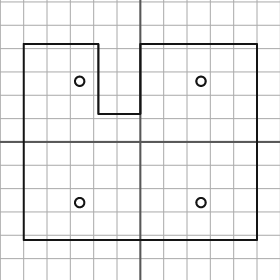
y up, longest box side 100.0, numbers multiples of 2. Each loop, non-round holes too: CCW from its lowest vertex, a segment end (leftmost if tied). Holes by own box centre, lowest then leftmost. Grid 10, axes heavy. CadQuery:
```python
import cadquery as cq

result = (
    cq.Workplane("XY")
    .moveTo(-50.0, -42.0)
    .lineTo(50.0, -42.0)
    .lineTo(50.0, 42.0)
    .lineTo(0.0, 42.0)
    .lineTo(0.0, 12.0)
    .lineTo(-18.0, 12.0)
    .lineTo(-18.0, 42.0)
    .lineTo(-50.0, 42.0)
    .close()
    .moveTo(-26.0, -26.0)
    .circle(2.0)
    .moveTo(26.0, -26.0)
    .circle(2.0)
    .moveTo(-26.0, 26.0)
    .circle(2.0)
    .moveTo(26.0, 26.0)
    .circle(2.0)
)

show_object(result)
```